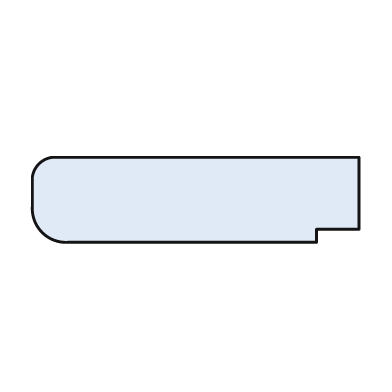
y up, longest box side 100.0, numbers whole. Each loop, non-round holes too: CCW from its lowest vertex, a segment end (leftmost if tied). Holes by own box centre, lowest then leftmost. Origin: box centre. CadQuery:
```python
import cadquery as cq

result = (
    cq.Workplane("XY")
    .moveTo(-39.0, -13.0)
    .lineTo(37.0, -13.0)
    .lineTo(37.0, -9.0)
    .lineTo(50.0, -9.0)
    .lineTo(50.0, 13.0)
    .lineTo(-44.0, 13.0)
    .threePointArc((-48.0, 11.0), (-50.0, 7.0))
    .lineTo(-50.0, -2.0)
    .threePointArc((-47.0, -10.0), (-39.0, -13.0))
    .close()
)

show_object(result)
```